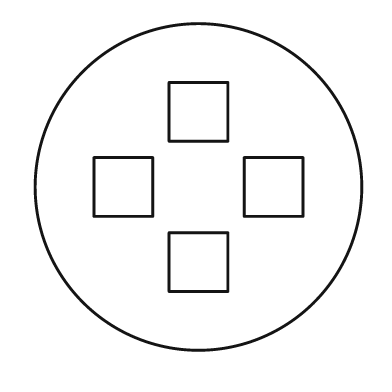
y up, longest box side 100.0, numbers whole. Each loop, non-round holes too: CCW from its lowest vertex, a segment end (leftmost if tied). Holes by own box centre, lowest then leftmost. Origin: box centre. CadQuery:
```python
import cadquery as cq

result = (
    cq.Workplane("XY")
    .moveTo(0.0, 0.0)
    .circle(50.0)
    .moveTo(-9.0, -32.0)
    .lineTo(9.0, -32.0)
    .lineTo(9.0, -14.0)
    .lineTo(-9.0, -14.0)
    .close()
    .moveTo(-32.0, -9.0)
    .lineTo(-14.0, -9.0)
    .lineTo(-14.0, 9.0)
    .lineTo(-32.0, 9.0)
    .close()
    .moveTo(14.0, -9.0)
    .lineTo(32.0, -9.0)
    .lineTo(32.0, 9.0)
    .lineTo(14.0, 9.0)
    .close()
    .moveTo(-9.0, 14.0)
    .lineTo(9.0, 14.0)
    .lineTo(9.0, 32.0)
    .lineTo(-9.0, 32.0)
    .close()
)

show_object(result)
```